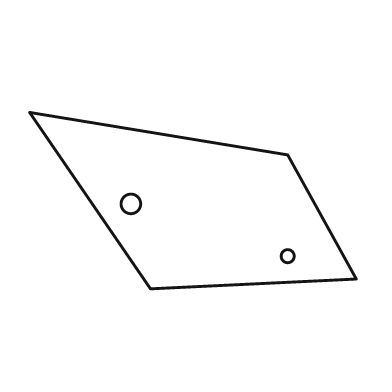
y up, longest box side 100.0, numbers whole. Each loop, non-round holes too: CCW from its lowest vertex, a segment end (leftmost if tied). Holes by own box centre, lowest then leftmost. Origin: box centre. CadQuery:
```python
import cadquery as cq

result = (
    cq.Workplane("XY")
    .moveTo(-13.0, -27.0)
    .lineTo(50.0, -24.0)
    .lineTo(29.0, 14.0)
    .lineTo(-50.0, 27.0)
    .close()
    .moveTo(29.0, -17.0)
    .circle(2.0)
    .moveTo(-19.0, -1.0)
    .circle(3.0)
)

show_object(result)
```